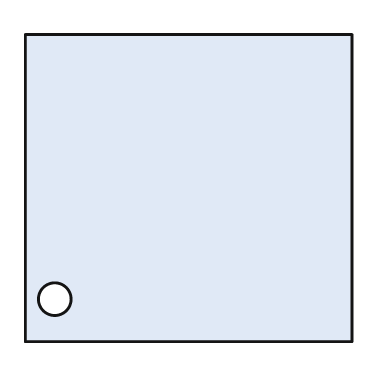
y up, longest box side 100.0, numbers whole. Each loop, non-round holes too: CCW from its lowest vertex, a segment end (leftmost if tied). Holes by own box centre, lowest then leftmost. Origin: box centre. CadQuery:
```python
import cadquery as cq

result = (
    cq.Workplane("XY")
    .moveTo(-50.0, -47.0)
    .lineTo(50.0, -47.0)
    .lineTo(50.0, 47.0)
    .lineTo(-50.0, 47.0)
    .close()
    .moveTo(-41.0, -34.0)
    .circle(5.0)
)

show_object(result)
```